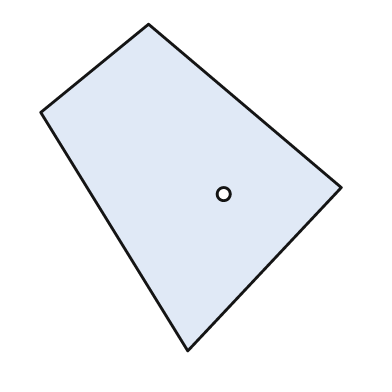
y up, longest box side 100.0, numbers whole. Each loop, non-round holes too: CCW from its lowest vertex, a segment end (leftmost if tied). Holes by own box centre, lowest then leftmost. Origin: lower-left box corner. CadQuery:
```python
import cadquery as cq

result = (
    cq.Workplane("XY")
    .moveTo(45.0, 0.0)
    .lineTo(92.0, 50.0)
    .lineTo(33.0, 100.0)
    .lineTo(0.0, 73.0)
    .close()
    .moveTo(56.0, 48.0)
    .circle(2.0)
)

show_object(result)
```